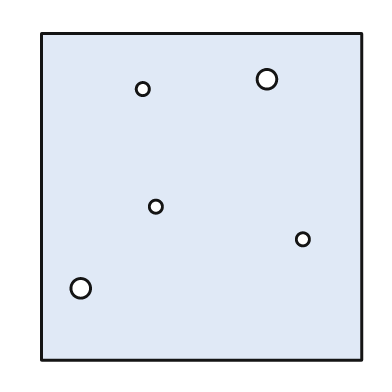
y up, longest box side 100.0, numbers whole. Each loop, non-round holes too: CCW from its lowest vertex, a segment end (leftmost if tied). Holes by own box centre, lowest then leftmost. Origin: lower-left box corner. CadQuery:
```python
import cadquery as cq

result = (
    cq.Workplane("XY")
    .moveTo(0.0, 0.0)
    .lineTo(98.0, 0.0)
    .lineTo(98.0, 100.0)
    .lineTo(0.0, 100.0)
    .close()
    .moveTo(12.0, 22.0)
    .circle(3.0)
    .moveTo(80.0, 37.0)
    .circle(2.0)
    .moveTo(35.0, 47.0)
    .circle(2.0)
    .moveTo(31.0, 83.0)
    .circle(2.0)
    .moveTo(69.0, 86.0)
    .circle(3.0)
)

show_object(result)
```